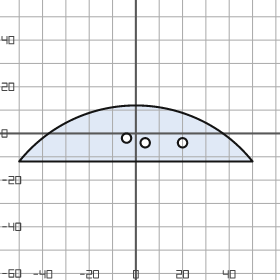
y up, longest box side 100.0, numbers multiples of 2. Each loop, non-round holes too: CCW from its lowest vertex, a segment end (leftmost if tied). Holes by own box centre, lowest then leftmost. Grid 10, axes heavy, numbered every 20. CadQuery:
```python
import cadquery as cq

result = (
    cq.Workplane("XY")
    .moveTo(-50.0, -12.0)
    .lineTo(50.0, -12.0)
    .threePointArc((0.0, 12.0), (-50.0, -12.0))
    .close()
    .moveTo(4.0, -4.0)
    .circle(2.0)
    .moveTo(20.0, -4.0)
    .circle(2.0)
    .moveTo(-4.0, -2.0)
    .circle(2.0)
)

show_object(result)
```